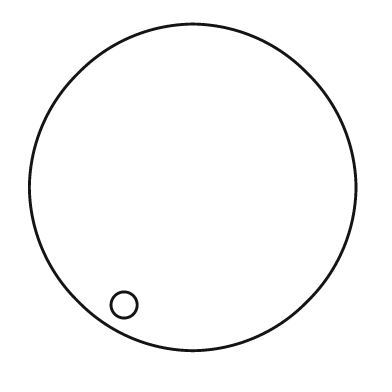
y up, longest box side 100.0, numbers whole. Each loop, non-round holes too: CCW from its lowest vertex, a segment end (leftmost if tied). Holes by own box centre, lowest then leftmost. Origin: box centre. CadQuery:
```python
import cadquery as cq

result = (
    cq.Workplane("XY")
    .moveTo(0.0, -50.0)
    .threePointArc((19.0, -46.0), (35.0, -35.0))
    .threePointArc((46.0, -19.0), (50.0, 0.0))
    .threePointArc((46.0, 19.0), (35.0, 35.0))
    .threePointArc((19.0, 46.0), (0.0, 50.0))
    .threePointArc((-19.0, 46.0), (-35.0, 35.0))
    .threePointArc((-46.0, 19.0), (-50.0, 0.0))
    .threePointArc((-46.0, -19.0), (-35.0, -35.0))
    .threePointArc((-19.0, -46.0), (0.0, -50.0))
    .close()
    .moveTo(-21.0, -36.0)
    .circle(4.0)
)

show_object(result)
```